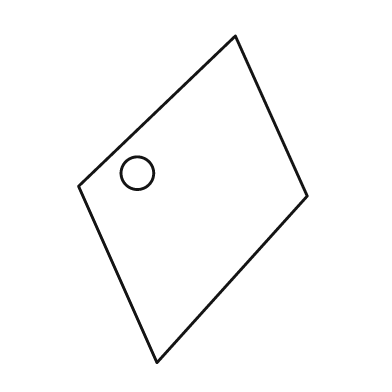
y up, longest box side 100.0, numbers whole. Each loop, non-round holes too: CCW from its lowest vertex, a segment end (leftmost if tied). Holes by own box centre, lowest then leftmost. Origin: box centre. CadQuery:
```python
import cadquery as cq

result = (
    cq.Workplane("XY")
    .moveTo(-11.0, -50.0)
    .lineTo(35.0, 1.0)
    .lineTo(13.0, 50.0)
    .lineTo(-35.0, 4.0)
    .close()
    .moveTo(-17.0, 8.0)
    .circle(5.0)
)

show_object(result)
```